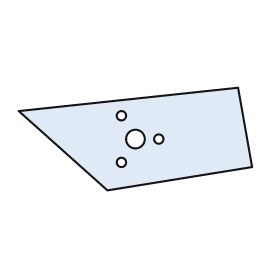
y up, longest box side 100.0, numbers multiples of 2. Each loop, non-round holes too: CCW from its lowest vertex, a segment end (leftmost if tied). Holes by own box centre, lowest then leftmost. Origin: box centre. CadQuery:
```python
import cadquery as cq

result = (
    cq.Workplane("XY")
    .moveTo(-12.0, -22.0)
    .lineTo(50.0, -12.0)
    .lineTo(44.0, 22.0)
    .lineTo(-50.0, 12.0)
    .close()
    .moveTo(-6.0, -10.0)
    .circle(2.0)
    .moveTo(0.0, 0.0)
    .circle(4.0)
    .moveTo(10.0, 0.0)
    .circle(2.0)
    .moveTo(-6.0, 10.0)
    .circle(2.0)
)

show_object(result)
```